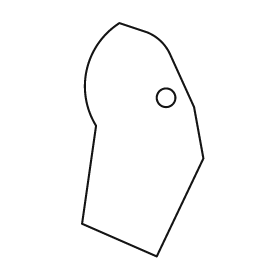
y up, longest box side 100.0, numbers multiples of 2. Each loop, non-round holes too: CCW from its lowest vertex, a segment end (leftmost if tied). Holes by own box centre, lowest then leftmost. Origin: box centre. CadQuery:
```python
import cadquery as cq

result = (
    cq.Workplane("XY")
    .moveTo(6.0, -50.0)
    .lineTo(26.0, -8.0)
    .lineTo(22.0, 14.0)
    .lineTo(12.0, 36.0)
    .threePointArc((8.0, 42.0), (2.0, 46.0))
    .lineTo(-10.0, 50.0)
    .threePointArc((-24.0, 30.0), (-20.0, 6.0))
    .lineTo(-26.0, -36.0)
    .close()
    .moveTo(10.0, 18.0)
    .circle(4.0)
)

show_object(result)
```